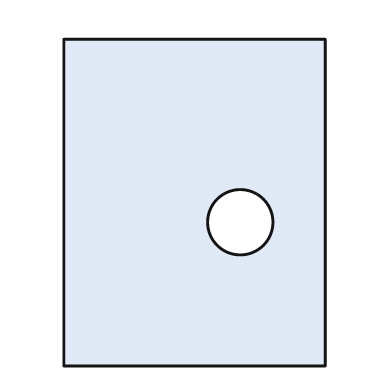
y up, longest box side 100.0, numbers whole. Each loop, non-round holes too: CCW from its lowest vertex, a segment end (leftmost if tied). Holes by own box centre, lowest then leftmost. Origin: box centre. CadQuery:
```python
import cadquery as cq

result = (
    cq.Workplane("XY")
    .moveTo(-40.0, -50.0)
    .lineTo(40.0, -50.0)
    .lineTo(40.0, 50.0)
    .lineTo(-40.0, 50.0)
    .close()
    .moveTo(14.0, -6.0)
    .circle(10.0)
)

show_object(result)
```